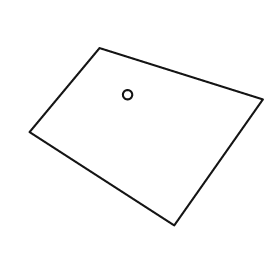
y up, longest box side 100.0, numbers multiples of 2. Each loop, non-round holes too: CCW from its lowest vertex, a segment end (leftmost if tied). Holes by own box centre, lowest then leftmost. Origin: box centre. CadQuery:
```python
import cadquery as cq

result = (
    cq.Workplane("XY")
    .moveTo(12.0, -38.0)
    .lineTo(50.0, 16.0)
    .lineTo(-20.0, 38.0)
    .lineTo(-50.0, 2.0)
    .close()
    .moveTo(-8.0, 18.0)
    .circle(2.0)
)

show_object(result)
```